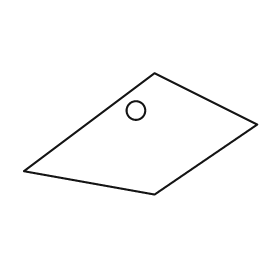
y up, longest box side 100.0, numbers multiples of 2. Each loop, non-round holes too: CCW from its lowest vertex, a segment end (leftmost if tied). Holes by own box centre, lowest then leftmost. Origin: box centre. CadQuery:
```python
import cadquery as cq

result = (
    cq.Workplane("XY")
    .moveTo(6.0, -26.0)
    .lineTo(50.0, 4.0)
    .lineTo(6.0, 26.0)
    .lineTo(-50.0, -16.0)
    .close()
    .moveTo(-2.0, 10.0)
    .circle(4.0)
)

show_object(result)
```